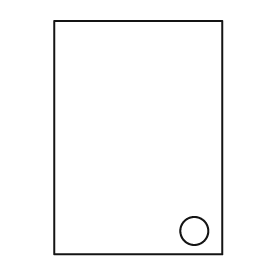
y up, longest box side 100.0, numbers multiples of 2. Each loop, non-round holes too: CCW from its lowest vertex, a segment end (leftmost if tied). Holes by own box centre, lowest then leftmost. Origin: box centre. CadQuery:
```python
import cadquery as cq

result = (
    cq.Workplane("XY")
    .moveTo(-36.0, -50.0)
    .lineTo(36.0, -50.0)
    .lineTo(36.0, 50.0)
    .lineTo(-36.0, 50.0)
    .close()
    .moveTo(24.0, -40.0)
    .circle(6.0)
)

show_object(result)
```